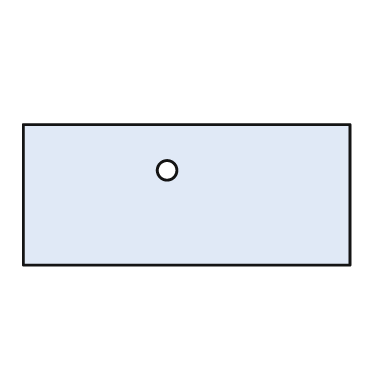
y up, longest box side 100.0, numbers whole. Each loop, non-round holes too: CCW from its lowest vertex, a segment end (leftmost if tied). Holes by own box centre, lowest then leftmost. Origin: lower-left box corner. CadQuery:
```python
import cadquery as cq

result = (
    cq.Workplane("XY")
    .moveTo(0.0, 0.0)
    .lineTo(100.0, 0.0)
    .lineTo(100.0, 43.0)
    .lineTo(0.0, 43.0)
    .close()
    .moveTo(44.0, 29.0)
    .circle(3.0)
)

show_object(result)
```